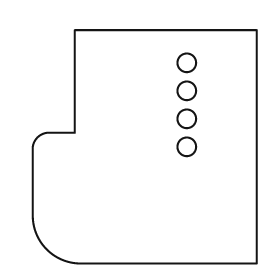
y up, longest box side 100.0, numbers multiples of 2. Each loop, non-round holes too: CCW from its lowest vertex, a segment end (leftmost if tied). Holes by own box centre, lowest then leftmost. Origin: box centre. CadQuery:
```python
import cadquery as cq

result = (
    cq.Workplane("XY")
    .moveTo(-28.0, -50.0)
    .lineTo(48.0, -50.0)
    .lineTo(48.0, 50.0)
    .lineTo(-30.0, 50.0)
    .lineTo(-30.0, 6.0)
    .lineTo(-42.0, 6.0)
    .threePointArc((-46.0, 4.0), (-48.0, 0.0))
    .lineTo(-48.0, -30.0)
    .threePointArc((-42.0, -44.0), (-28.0, -50.0))
    .close()
    .moveTo(18.0, 0.0)
    .circle(4.0)
    .moveTo(18.0, 12.0)
    .circle(4.0)
    .moveTo(18.0, 24.0)
    .circle(4.0)
    .moveTo(18.0, 36.0)
    .circle(4.0)
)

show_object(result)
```